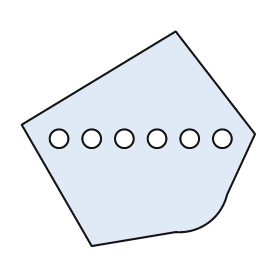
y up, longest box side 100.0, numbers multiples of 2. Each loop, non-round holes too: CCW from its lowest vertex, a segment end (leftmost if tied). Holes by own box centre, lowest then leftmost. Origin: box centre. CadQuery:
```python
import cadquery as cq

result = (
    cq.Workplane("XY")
    .moveTo(-20.0, -46.0)
    .lineTo(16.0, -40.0)
    .threePointArc((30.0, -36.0), (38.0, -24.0))
    .lineTo(50.0, 2.0)
    .lineTo(16.0, 46.0)
    .lineTo(-50.0, 6.0)
    .close()
    .moveTo(-34.0, 0.0)
    .circle(4.0)
    .moveTo(-20.0, 0.0)
    .circle(4.0)
    .moveTo(-6.0, 0.0)
    .circle(4.0)
    .moveTo(8.0, 0.0)
    .circle(4.0)
    .moveTo(22.0, 0.0)
    .circle(4.0)
    .moveTo(36.0, 0.0)
    .circle(4.0)
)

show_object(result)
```